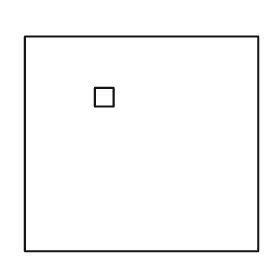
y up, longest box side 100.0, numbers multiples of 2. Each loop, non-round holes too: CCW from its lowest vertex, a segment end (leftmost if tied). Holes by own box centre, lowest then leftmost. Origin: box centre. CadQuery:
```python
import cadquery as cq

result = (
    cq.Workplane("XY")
    .moveTo(-50.0, -46.0)
    .lineTo(50.0, -46.0)
    .lineTo(50.0, 46.0)
    .lineTo(-50.0, 46.0)
    .close()
    .moveTo(-20.0, 16.0)
    .lineTo(-12.0, 16.0)
    .lineTo(-12.0, 24.0)
    .lineTo(-20.0, 24.0)
    .close()
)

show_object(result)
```